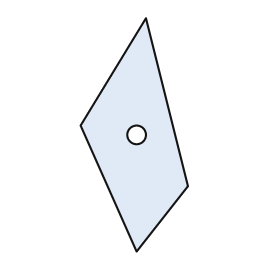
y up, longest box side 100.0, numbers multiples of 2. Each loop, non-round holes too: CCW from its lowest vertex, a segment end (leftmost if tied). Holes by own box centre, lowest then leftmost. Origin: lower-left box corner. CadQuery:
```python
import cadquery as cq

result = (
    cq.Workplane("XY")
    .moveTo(24.0, 0.0)
    .lineTo(46.0, 28.0)
    .lineTo(28.0, 100.0)
    .lineTo(0.0, 54.0)
    .close()
    .moveTo(24.0, 50.0)
    .circle(4.0)
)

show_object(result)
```